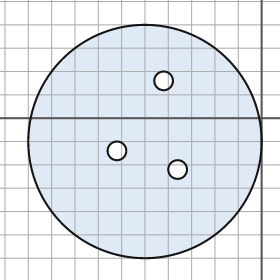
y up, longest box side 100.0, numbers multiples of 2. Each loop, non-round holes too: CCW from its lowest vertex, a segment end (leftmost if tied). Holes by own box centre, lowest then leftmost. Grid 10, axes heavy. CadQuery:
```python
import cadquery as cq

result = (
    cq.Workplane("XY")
    .moveTo(-50.0, -10.0)
    .circle(50.0)
    .moveTo(-36.0, -22.0)
    .circle(4.0)
    .moveTo(-62.0, -14.0)
    .circle(4.0)
    .moveTo(-42.0, 16.0)
    .circle(4.0)
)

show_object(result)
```